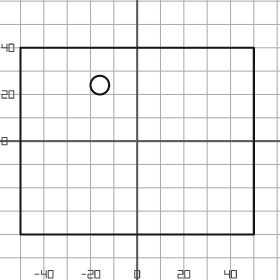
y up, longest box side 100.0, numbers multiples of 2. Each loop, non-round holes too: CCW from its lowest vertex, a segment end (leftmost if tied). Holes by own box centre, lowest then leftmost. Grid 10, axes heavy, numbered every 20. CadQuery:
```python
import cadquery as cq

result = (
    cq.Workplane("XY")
    .moveTo(-50.0, -40.0)
    .lineTo(50.0, -40.0)
    .lineTo(50.0, 40.0)
    .lineTo(-50.0, 40.0)
    .close()
    .moveTo(-16.0, 24.0)
    .circle(4.0)
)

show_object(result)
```